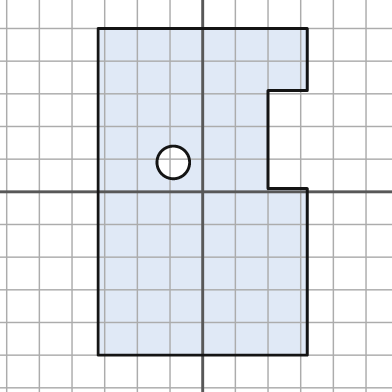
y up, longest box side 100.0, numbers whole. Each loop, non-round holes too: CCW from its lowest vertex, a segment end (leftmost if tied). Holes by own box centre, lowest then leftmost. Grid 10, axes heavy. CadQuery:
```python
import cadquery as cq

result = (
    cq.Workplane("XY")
    .moveTo(-32.0, -50.0)
    .lineTo(32.0, -50.0)
    .lineTo(32.0, 1.0)
    .lineTo(20.0, 1.0)
    .lineTo(20.0, 31.0)
    .lineTo(32.0, 31.0)
    .lineTo(32.0, 50.0)
    .lineTo(-32.0, 50.0)
    .close()
    .moveTo(-9.0, 9.0)
    .circle(5.0)
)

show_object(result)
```